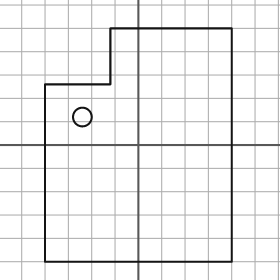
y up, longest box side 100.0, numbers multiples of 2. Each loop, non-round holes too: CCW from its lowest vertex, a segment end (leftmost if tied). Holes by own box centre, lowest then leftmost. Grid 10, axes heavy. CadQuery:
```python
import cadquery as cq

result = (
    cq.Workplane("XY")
    .moveTo(-40.0, -50.0)
    .lineTo(40.0, -50.0)
    .lineTo(40.0, 50.0)
    .lineTo(-12.0, 50.0)
    .lineTo(-12.0, 26.0)
    .lineTo(-40.0, 26.0)
    .close()
    .moveTo(-24.0, 12.0)
    .circle(4.0)
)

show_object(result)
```